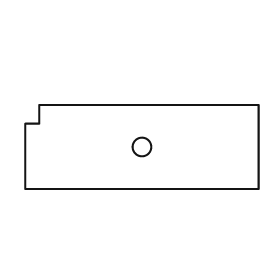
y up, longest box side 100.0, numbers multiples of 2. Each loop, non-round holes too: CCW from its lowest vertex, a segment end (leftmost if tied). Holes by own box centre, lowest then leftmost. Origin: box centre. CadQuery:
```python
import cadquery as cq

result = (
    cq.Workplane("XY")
    .moveTo(-50.0, -18.0)
    .lineTo(50.0, -18.0)
    .lineTo(50.0, 18.0)
    .lineTo(-44.0, 18.0)
    .lineTo(-44.0, 10.0)
    .lineTo(-50.0, 10.0)
    .close()
    .moveTo(0.0, 0.0)
    .circle(4.0)
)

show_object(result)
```